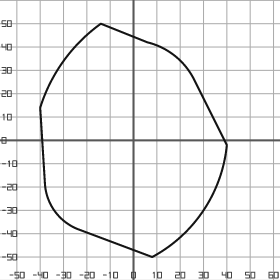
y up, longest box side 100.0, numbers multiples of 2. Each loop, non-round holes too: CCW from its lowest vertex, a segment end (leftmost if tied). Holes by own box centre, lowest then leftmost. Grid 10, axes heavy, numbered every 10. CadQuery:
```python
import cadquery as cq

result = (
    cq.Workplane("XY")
    .moveTo(8.0, -50.0)
    .threePointArc((30.0, -30.0), (40.0, -2.0))
    .lineTo(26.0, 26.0)
    .threePointArc((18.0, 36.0), (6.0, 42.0))
    .lineTo(-14.0, 50.0)
    .threePointArc((-30.0, 34.0), (-40.0, 14.0))
    .lineTo(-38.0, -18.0)
    .threePointArc((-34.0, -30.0), (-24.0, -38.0))
    .close()
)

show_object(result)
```